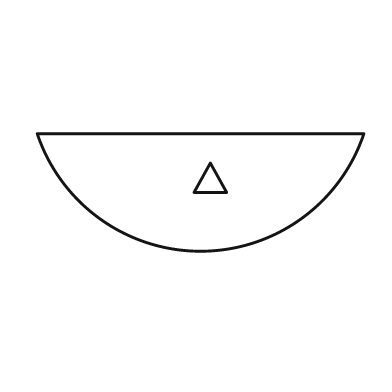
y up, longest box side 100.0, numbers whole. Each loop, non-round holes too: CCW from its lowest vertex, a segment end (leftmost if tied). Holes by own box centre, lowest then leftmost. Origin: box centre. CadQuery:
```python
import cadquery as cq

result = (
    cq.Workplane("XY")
    .moveTo(-50.0, 18.0)
    .threePointArc((0.0, -18.0), (50.0, 18.0))
    .close()
    .moveTo(-2.0, 0.0)
    .lineTo(8.0, 0.0)
    .lineTo(3.0, 9.0)
    .close()
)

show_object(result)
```